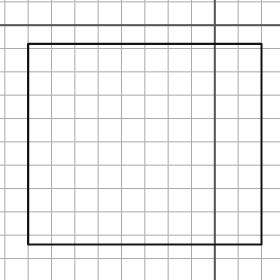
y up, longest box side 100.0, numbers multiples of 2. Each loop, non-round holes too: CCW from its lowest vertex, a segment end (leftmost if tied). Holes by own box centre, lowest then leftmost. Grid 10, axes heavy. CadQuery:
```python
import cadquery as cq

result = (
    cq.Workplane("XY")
    .moveTo(-80.0, -94.0)
    .lineTo(20.0, -94.0)
    .lineTo(20.0, -8.0)
    .lineTo(-80.0, -8.0)
    .close()
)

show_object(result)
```